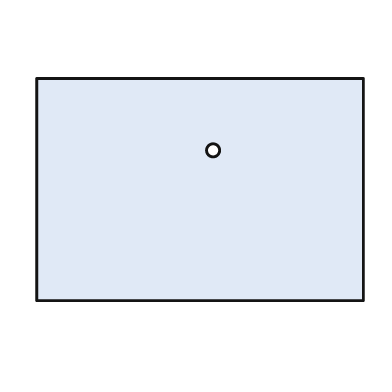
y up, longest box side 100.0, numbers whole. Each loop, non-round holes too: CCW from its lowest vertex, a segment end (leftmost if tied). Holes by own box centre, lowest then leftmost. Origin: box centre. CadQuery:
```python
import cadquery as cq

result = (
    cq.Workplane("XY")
    .moveTo(-50.0, -34.0)
    .lineTo(50.0, -34.0)
    .lineTo(50.0, 34.0)
    .lineTo(-50.0, 34.0)
    .close()
    .moveTo(4.0, 12.0)
    .circle(2.0)
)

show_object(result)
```